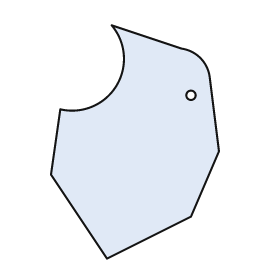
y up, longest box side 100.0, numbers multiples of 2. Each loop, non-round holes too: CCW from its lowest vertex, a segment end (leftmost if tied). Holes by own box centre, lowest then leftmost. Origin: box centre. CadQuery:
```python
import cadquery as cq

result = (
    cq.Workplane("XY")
    .moveTo(-12.0, -50.0)
    .lineTo(24.0, -32.0)
    .lineTo(36.0, -4.0)
    .lineTo(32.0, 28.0)
    .threePointArc((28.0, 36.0), (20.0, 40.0))
    .lineTo(-10.0, 50.0)
    .threePointArc((-8.0, 24.0), (-32.0, 14.0))
    .lineTo(-36.0, -14.0)
    .close()
    .moveTo(24.0, 20.0)
    .circle(2.0)
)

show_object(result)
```